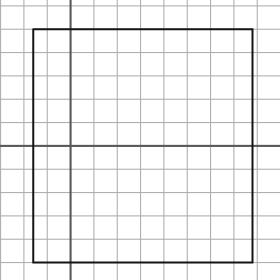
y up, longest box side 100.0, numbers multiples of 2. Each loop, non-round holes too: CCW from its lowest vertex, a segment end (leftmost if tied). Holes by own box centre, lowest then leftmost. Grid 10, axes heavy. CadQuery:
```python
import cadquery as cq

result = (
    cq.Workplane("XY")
    .moveTo(-16.0, -50.0)
    .lineTo(78.0, -50.0)
    .lineTo(78.0, 50.0)
    .lineTo(-16.0, 50.0)
    .close()
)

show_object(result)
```